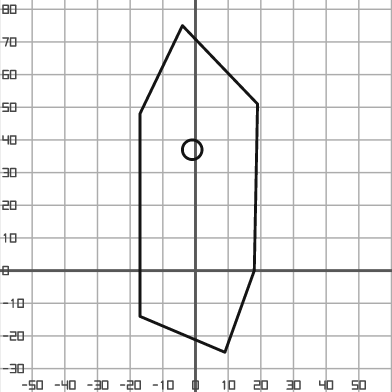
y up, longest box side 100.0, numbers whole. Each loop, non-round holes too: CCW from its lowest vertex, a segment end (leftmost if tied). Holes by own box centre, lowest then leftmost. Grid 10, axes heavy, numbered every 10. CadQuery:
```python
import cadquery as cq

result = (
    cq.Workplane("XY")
    .moveTo(9.0, -25.0)
    .lineTo(18.0, 0.0)
    .lineTo(19.0, 51.0)
    .lineTo(-4.0, 75.0)
    .lineTo(-17.0, 48.0)
    .lineTo(-17.0, -14.0)
    .close()
    .moveTo(-1.0, 37.0)
    .circle(3.0)
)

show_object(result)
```